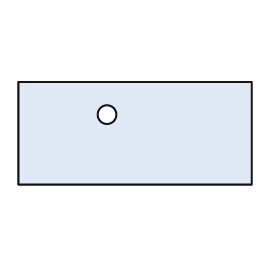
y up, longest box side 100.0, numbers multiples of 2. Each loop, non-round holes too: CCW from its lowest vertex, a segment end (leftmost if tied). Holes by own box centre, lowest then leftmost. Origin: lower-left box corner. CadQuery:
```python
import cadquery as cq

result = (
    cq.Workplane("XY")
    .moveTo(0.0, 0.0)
    .lineTo(100.0, 0.0)
    .lineTo(100.0, 44.0)
    .lineTo(0.0, 44.0)
    .close()
    .moveTo(38.0, 30.0)
    .circle(4.0)
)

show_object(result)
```